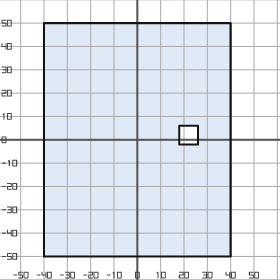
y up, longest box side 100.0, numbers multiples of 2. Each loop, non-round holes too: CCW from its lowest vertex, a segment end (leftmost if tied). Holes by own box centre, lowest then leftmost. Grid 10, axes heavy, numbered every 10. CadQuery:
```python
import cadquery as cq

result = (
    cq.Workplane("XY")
    .moveTo(-40.0, -50.0)
    .lineTo(40.0, -50.0)
    .lineTo(40.0, 50.0)
    .lineTo(-40.0, 50.0)
    .close()
    .moveTo(18.0, -2.0)
    .lineTo(26.0, -2.0)
    .lineTo(26.0, 6.0)
    .lineTo(18.0, 6.0)
    .close()
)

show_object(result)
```